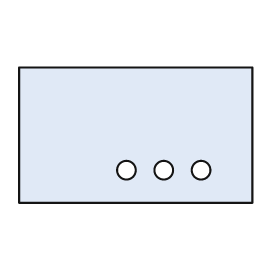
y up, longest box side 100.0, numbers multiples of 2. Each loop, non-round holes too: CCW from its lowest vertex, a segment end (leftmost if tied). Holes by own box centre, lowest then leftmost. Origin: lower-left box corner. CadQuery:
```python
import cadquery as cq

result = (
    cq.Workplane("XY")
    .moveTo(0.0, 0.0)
    .lineTo(100.0, 0.0)
    .lineTo(100.0, 58.0)
    .lineTo(0.0, 58.0)
    .close()
    .moveTo(46.0, 14.0)
    .circle(4.0)
    .moveTo(62.0, 14.0)
    .circle(4.0)
    .moveTo(78.0, 14.0)
    .circle(4.0)
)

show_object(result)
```